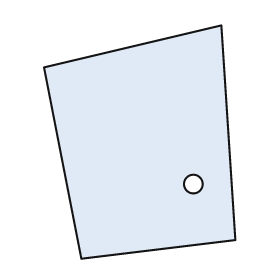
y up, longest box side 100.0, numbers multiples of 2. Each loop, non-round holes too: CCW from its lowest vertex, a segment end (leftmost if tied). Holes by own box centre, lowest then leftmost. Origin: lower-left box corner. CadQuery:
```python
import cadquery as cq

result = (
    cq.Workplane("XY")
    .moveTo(16.0, 0.0)
    .lineTo(82.0, 8.0)
    .lineTo(76.0, 100.0)
    .lineTo(0.0, 82.0)
    .close()
    .moveTo(64.0, 32.0)
    .circle(4.0)
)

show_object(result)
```